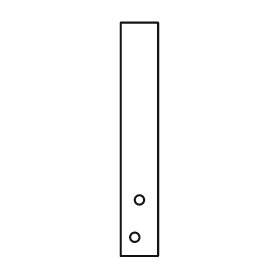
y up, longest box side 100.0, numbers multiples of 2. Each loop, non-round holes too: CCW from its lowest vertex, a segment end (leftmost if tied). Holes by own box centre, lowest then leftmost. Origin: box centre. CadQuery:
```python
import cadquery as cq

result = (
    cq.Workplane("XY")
    .moveTo(-8.0, -50.0)
    .lineTo(8.0, -50.0)
    .lineTo(8.0, 50.0)
    .lineTo(-8.0, 50.0)
    .close()
    .moveTo(-2.0, -42.0)
    .circle(2.0)
    .moveTo(0.0, -26.0)
    .circle(2.0)
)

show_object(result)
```